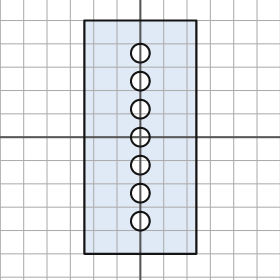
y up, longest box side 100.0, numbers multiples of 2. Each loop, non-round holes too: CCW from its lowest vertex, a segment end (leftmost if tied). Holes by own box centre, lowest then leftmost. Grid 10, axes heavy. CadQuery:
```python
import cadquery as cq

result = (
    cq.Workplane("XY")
    .moveTo(-24.0, -50.0)
    .lineTo(24.0, -50.0)
    .lineTo(24.0, 50.0)
    .lineTo(-24.0, 50.0)
    .close()
    .moveTo(0.0, -36.0)
    .circle(4.0)
    .moveTo(0.0, -24.0)
    .circle(4.0)
    .moveTo(0.0, -12.0)
    .circle(4.0)
    .moveTo(0.0, 0.0)
    .circle(4.0)
    .moveTo(0.0, 12.0)
    .circle(4.0)
    .moveTo(0.0, 24.0)
    .circle(4.0)
    .moveTo(0.0, 36.0)
    .circle(4.0)
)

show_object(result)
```